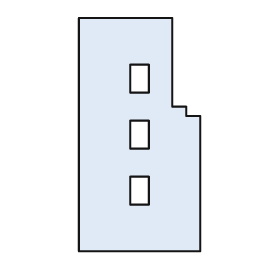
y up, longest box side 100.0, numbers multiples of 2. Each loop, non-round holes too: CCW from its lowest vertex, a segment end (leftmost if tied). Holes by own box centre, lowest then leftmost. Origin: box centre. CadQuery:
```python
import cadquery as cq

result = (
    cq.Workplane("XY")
    .moveTo(-26.0, -50.0)
    .lineTo(26.0, -50.0)
    .lineTo(26.0, 8.0)
    .lineTo(20.0, 8.0)
    .lineTo(20.0, 12.0)
    .lineTo(14.0, 12.0)
    .lineTo(14.0, 50.0)
    .lineTo(-26.0, 50.0)
    .close()
    .moveTo(-4.0, -30.0)
    .lineTo(4.0, -30.0)
    .lineTo(4.0, -18.0)
    .lineTo(-4.0, -18.0)
    .close()
    .moveTo(-4.0, -6.0)
    .lineTo(4.0, -6.0)
    .lineTo(4.0, 6.0)
    .lineTo(-4.0, 6.0)
    .close()
    .moveTo(-4.0, 18.0)
    .lineTo(4.0, 18.0)
    .lineTo(4.0, 30.0)
    .lineTo(-4.0, 30.0)
    .close()
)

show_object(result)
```